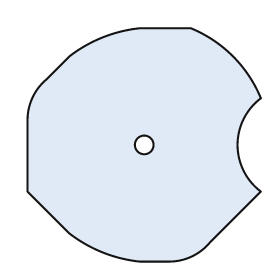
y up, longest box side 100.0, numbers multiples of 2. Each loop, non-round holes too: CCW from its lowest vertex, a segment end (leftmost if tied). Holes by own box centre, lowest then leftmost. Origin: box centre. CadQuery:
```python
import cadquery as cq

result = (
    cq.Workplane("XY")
    .moveTo(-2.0, -50.0)
    .lineTo(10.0, -50.0)
    .threePointArc((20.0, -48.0), (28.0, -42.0))
    .lineTo(50.0, -20.0)
    .threePointArc((40.0, 0.0), (50.0, 20.0))
    .threePointArc((38.0, 38.0), (20.0, 50.0))
    .lineTo(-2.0, 50.0)
    .threePointArc((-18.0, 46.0), (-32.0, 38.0))
    .lineTo(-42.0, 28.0)
    .threePointArc((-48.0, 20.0), (-50.0, 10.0))
    .lineTo(-50.0, -20.0)
    .lineTo(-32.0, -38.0)
    .threePointArc((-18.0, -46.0), (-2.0, -50.0))
    .close()
    .moveTo(0.0, 0.0)
    .circle(4.0)
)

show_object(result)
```